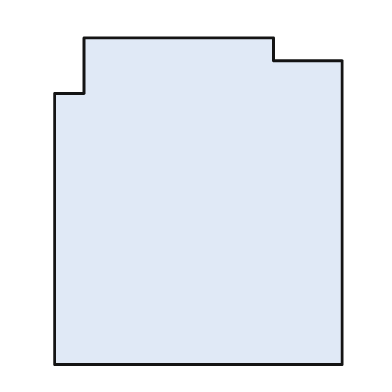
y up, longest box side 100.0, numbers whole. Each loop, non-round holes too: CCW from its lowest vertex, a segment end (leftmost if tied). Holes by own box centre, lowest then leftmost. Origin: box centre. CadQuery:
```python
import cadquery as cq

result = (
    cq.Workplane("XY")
    .moveTo(-44.0, -50.0)
    .lineTo(44.0, -50.0)
    .lineTo(44.0, 43.0)
    .lineTo(23.0, 43.0)
    .lineTo(23.0, 50.0)
    .lineTo(-35.0, 50.0)
    .lineTo(-35.0, 33.0)
    .lineTo(-44.0, 33.0)
    .close()
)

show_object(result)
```